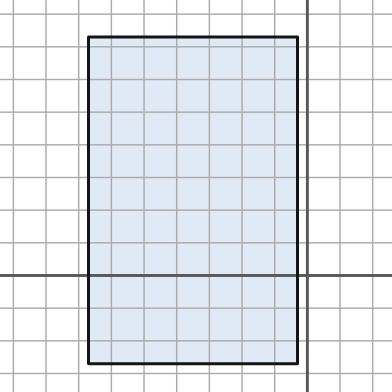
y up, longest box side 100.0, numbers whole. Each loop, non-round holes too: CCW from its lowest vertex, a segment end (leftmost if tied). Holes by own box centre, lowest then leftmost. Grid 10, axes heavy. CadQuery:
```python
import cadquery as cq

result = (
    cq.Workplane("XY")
    .moveTo(-67.0, -27.0)
    .lineTo(-3.0, -27.0)
    .lineTo(-3.0, 73.0)
    .lineTo(-67.0, 73.0)
    .close()
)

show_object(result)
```